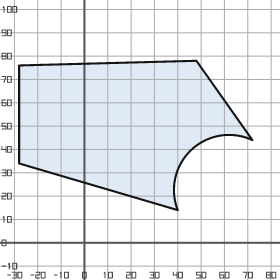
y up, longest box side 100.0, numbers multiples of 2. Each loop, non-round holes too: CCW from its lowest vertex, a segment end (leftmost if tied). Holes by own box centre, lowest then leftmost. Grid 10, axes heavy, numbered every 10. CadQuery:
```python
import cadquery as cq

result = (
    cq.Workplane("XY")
    .moveTo(40.0, 14.0)
    .threePointArc((46.0, 40.0), (72.0, 44.0))
    .lineTo(48.0, 78.0)
    .lineTo(-28.0, 76.0)
    .lineTo(-28.0, 34.0)
    .close()
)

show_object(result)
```